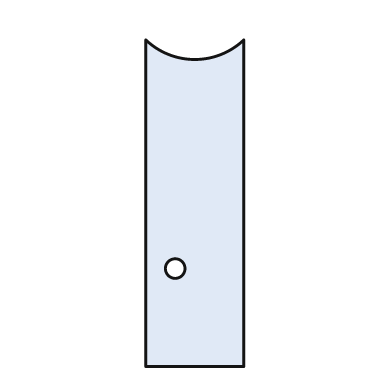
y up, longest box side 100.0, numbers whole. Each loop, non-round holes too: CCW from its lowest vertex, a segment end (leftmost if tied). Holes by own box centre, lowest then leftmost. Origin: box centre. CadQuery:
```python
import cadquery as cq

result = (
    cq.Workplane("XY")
    .moveTo(-15.0, -50.0)
    .lineTo(15.0, -50.0)
    .lineTo(15.0, 50.0)
    .threePointArc((0.0, 44.0), (-15.0, 50.0))
    .close()
    .moveTo(-6.0, -20.0)
    .circle(3.0)
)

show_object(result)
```